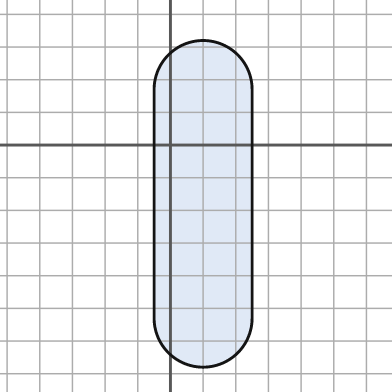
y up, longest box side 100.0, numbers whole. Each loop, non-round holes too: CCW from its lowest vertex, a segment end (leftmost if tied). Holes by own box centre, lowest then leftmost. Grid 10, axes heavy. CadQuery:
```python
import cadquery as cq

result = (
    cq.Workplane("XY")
    .moveTo(-5.0, -53.0)
    .threePointArc((10.0, -68.0), (25.0, -53.0))
    .lineTo(25.0, 17.0)
    .threePointArc((10.0, 32.0), (-5.0, 17.0))
    .close()
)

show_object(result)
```